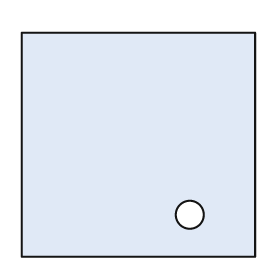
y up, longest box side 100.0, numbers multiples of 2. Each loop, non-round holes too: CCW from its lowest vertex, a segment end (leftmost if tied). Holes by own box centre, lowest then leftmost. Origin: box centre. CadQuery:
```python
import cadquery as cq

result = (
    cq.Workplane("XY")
    .moveTo(-50.0, -48.0)
    .lineTo(50.0, -48.0)
    .lineTo(50.0, 48.0)
    .lineTo(-50.0, 48.0)
    .close()
    .moveTo(22.0, -30.0)
    .circle(6.0)
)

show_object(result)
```